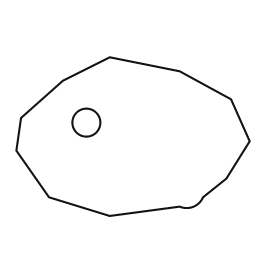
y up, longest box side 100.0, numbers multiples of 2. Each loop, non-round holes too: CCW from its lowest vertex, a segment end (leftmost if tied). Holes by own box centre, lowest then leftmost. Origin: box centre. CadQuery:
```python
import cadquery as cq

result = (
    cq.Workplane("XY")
    .moveTo(-10.0, -34.0)
    .lineTo(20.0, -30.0)
    .threePointArc((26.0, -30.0), (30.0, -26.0))
    .lineTo(40.0, -18.0)
    .lineTo(50.0, -2.0)
    .lineTo(42.0, 16.0)
    .lineTo(20.0, 28.0)
    .lineTo(-10.0, 34.0)
    .lineTo(-30.0, 24.0)
    .lineTo(-48.0, 8.0)
    .lineTo(-50.0, -6.0)
    .lineTo(-36.0, -26.0)
    .close()
    .moveTo(-20.0, 6.0)
    .circle(6.0)
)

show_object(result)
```